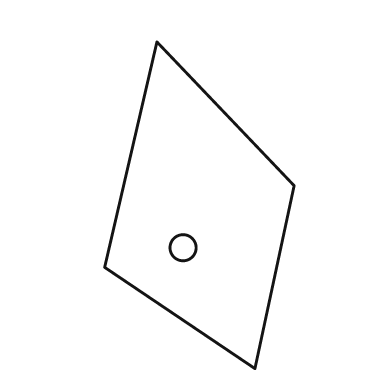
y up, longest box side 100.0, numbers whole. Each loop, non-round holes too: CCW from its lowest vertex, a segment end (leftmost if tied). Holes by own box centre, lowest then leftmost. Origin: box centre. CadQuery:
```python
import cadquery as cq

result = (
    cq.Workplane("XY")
    .moveTo(17.0, -50.0)
    .lineTo(29.0, 6.0)
    .lineTo(-13.0, 50.0)
    .lineTo(-29.0, -19.0)
    .close()
    .moveTo(-5.0, -13.0)
    .circle(4.0)
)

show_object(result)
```